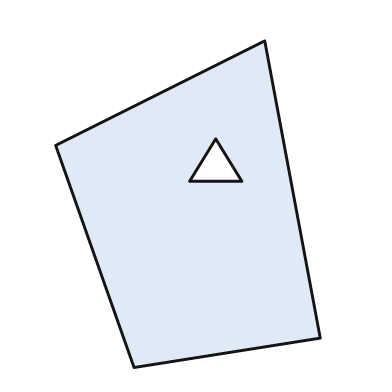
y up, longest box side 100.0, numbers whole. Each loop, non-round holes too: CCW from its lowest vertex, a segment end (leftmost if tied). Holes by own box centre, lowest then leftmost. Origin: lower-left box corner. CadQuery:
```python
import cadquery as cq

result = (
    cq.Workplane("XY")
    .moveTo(24.0, 0.0)
    .lineTo(81.0, 9.0)
    .lineTo(64.0, 100.0)
    .lineTo(0.0, 68.0)
    .close()
    .moveTo(41.0, 57.0)
    .lineTo(57.0, 57.0)
    .lineTo(49.0, 70.0)
    .close()
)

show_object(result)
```